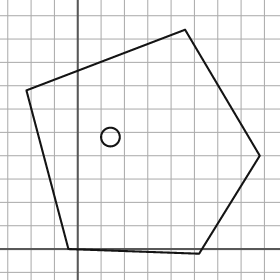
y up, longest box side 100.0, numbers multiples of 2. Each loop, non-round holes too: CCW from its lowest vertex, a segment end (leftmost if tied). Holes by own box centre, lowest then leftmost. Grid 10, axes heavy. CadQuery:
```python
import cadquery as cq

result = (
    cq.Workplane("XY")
    .moveTo(52.0, -2.0)
    .lineTo(78.0, 40.0)
    .lineTo(46.0, 94.0)
    .lineTo(-22.0, 68.0)
    .lineTo(-4.0, 0.0)
    .close()
    .moveTo(14.0, 48.0)
    .circle(4.0)
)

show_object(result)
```